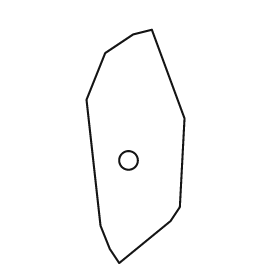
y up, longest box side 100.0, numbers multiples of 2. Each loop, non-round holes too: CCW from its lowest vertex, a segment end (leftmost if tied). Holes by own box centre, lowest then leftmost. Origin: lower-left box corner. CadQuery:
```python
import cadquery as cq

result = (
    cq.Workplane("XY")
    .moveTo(14.0, 0.0)
    .lineTo(36.0, 18.0)
    .lineTo(40.0, 24.0)
    .lineTo(42.0, 62.0)
    .lineTo(28.0, 100.0)
    .lineTo(20.0, 98.0)
    .lineTo(8.0, 90.0)
    .lineTo(0.0, 70.0)
    .lineTo(6.0, 16.0)
    .lineTo(10.0, 6.0)
    .close()
    .moveTo(18.0, 44.0)
    .circle(4.0)
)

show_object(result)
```